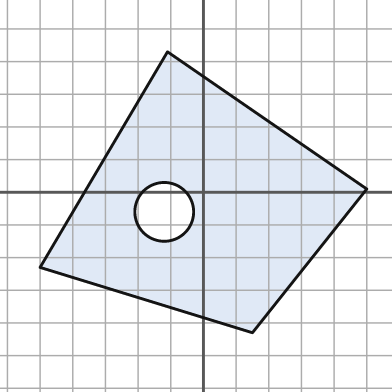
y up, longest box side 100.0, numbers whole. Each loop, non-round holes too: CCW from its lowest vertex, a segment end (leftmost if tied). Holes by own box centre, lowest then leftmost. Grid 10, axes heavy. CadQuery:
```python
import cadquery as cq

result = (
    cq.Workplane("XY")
    .moveTo(15.0, -43.0)
    .lineTo(50.0, 1.0)
    .lineTo(-11.0, 43.0)
    .lineTo(-50.0, -23.0)
    .close()
    .moveTo(-12.0, -6.0)
    .circle(9.0)
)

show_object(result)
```